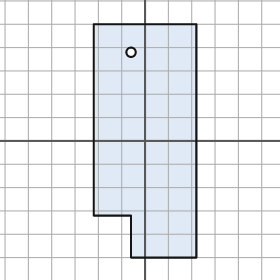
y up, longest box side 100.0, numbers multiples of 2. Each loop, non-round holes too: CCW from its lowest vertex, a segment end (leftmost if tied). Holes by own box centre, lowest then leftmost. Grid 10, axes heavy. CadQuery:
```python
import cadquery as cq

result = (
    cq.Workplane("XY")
    .moveTo(-6.0, -50.0)
    .lineTo(22.0, -50.0)
    .lineTo(22.0, 50.0)
    .lineTo(-22.0, 50.0)
    .lineTo(-22.0, -32.0)
    .lineTo(-6.0, -32.0)
    .close()
    .moveTo(-6.0, 38.0)
    .circle(2.0)
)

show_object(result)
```